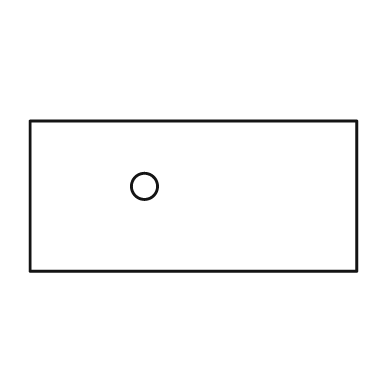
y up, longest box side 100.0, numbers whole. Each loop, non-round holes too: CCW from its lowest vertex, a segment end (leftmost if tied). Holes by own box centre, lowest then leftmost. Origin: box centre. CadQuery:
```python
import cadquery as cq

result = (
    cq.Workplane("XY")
    .moveTo(-50.0, -23.0)
    .lineTo(50.0, -23.0)
    .lineTo(50.0, 23.0)
    .lineTo(-50.0, 23.0)
    .close()
    .moveTo(-15.0, 3.0)
    .circle(4.0)
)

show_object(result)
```